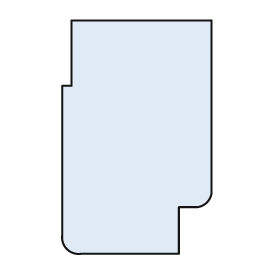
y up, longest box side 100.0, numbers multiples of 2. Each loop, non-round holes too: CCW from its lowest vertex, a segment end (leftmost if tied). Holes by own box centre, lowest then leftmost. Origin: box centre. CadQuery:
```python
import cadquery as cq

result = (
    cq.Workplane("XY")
    .moveTo(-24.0, -50.0)
    .lineTo(18.0, -50.0)
    .lineTo(18.0, -30.0)
    .lineTo(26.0, -30.0)
    .threePointArc((30.0, -28.0), (32.0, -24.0))
    .lineTo(32.0, 50.0)
    .lineTo(-28.0, 50.0)
    .lineTo(-28.0, 22.0)
    .lineTo(-32.0, 22.0)
    .lineTo(-32.0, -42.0)
    .threePointArc((-30.0, -48.0), (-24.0, -50.0))
    .close()
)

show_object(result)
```